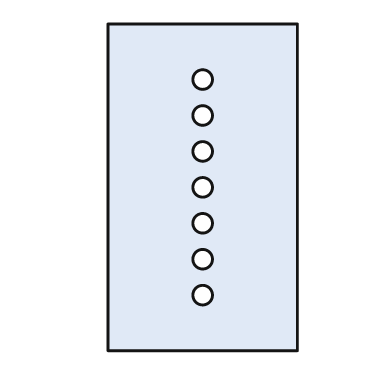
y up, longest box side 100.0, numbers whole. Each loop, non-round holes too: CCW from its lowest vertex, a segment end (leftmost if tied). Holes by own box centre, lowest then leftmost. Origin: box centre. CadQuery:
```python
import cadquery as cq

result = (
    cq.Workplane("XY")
    .moveTo(-29.0, -50.0)
    .lineTo(29.0, -50.0)
    .lineTo(29.0, 50.0)
    .lineTo(-29.0, 50.0)
    .close()
    .moveTo(0.0, -33.0)
    .circle(3.0)
    .moveTo(0.0, -22.0)
    .circle(3.0)
    .moveTo(0.0, -11.0)
    .circle(3.0)
    .moveTo(0.0, 0.0)
    .circle(3.0)
    .moveTo(0.0, 11.0)
    .circle(3.0)
    .moveTo(0.0, 22.0)
    .circle(3.0)
    .moveTo(0.0, 33.0)
    .circle(3.0)
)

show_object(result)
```